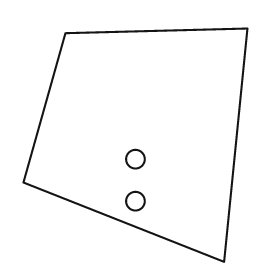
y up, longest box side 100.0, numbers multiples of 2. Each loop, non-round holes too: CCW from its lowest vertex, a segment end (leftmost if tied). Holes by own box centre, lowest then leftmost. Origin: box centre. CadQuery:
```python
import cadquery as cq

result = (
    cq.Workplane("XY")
    .moveTo(38.0, -50.0)
    .lineTo(48.0, 50.0)
    .lineTo(-30.0, 48.0)
    .lineTo(-48.0, -16.0)
    .close()
    .moveTo(0.0, -24.0)
    .circle(4.0)
    .moveTo(0.0, -6.0)
    .circle(4.0)
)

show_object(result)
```